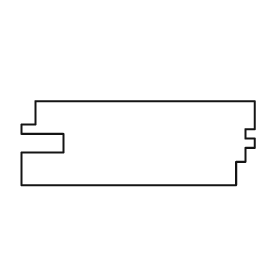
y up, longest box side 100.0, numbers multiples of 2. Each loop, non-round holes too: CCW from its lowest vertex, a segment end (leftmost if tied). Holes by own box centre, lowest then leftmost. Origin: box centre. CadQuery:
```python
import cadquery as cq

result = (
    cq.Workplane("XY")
    .moveTo(-50.0, -18.0)
    .lineTo(42.0, -18.0)
    .lineTo(42.0, -8.0)
    .lineTo(46.0, -8.0)
    .lineTo(46.0, -2.0)
    .lineTo(50.0, -2.0)
    .lineTo(50.0, 2.0)
    .lineTo(46.0, 2.0)
    .lineTo(46.0, 6.0)
    .lineTo(50.0, 6.0)
    .lineTo(50.0, 18.0)
    .lineTo(-44.0, 18.0)
    .lineTo(-44.0, 8.0)
    .lineTo(-50.0, 8.0)
    .lineTo(-50.0, 4.0)
    .lineTo(-32.0, 4.0)
    .lineTo(-32.0, -4.0)
    .lineTo(-50.0, -4.0)
    .close()
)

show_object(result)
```